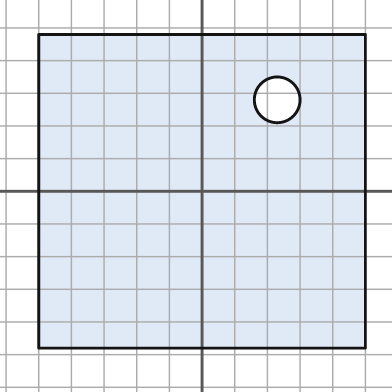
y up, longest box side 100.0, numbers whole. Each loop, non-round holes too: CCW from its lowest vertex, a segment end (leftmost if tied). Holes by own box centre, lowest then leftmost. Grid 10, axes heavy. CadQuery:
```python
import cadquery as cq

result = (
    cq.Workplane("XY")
    .moveTo(-50.0, -48.0)
    .lineTo(50.0, -48.0)
    .lineTo(50.0, 48.0)
    .lineTo(-50.0, 48.0)
    .close()
    .moveTo(23.0, 28.0)
    .circle(7.0)
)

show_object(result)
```